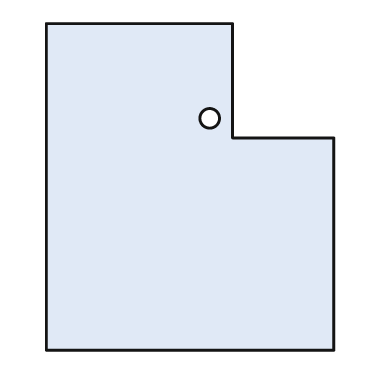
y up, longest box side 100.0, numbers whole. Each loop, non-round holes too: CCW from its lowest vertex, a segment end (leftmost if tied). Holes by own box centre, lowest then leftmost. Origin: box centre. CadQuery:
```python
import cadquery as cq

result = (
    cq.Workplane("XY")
    .moveTo(-44.0, -50.0)
    .lineTo(44.0, -50.0)
    .lineTo(44.0, 15.0)
    .lineTo(13.0, 15.0)
    .lineTo(13.0, 50.0)
    .lineTo(-44.0, 50.0)
    .close()
    .moveTo(6.0, 21.0)
    .circle(3.0)
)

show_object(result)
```